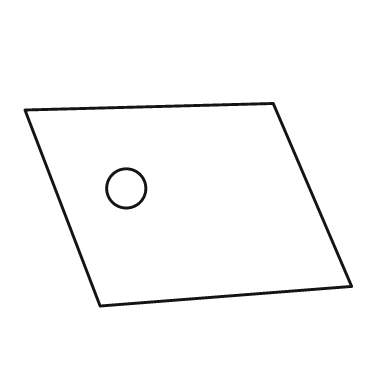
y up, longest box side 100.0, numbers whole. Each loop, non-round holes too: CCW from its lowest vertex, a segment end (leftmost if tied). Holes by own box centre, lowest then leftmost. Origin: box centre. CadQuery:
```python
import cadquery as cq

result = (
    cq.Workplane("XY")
    .moveTo(-27.0, -31.0)
    .lineTo(50.0, -25.0)
    .lineTo(26.0, 31.0)
    .lineTo(-50.0, 29.0)
    .close()
    .moveTo(-19.0, 5.0)
    .circle(6.0)
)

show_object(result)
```